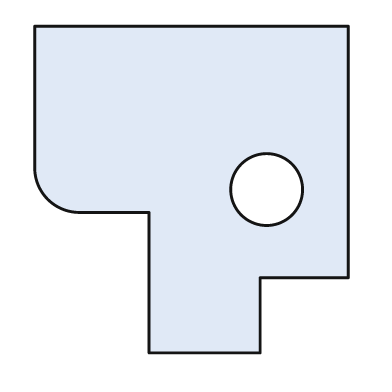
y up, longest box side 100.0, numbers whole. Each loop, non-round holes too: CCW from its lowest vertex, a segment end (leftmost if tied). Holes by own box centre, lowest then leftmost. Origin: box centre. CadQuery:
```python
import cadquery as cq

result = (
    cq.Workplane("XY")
    .moveTo(-13.0, -50.0)
    .lineTo(21.0, -50.0)
    .lineTo(21.0, -27.0)
    .lineTo(48.0, -27.0)
    .lineTo(48.0, 50.0)
    .lineTo(-48.0, 50.0)
    .lineTo(-48.0, 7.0)
    .threePointArc((-44.0, -3.0), (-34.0, -7.0))
    .lineTo(-13.0, -7.0)
    .close()
    .moveTo(23.0, 0.0)
    .circle(11.0)
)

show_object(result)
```